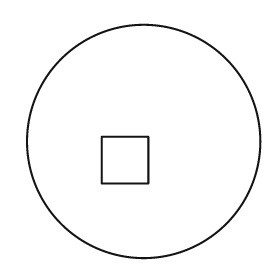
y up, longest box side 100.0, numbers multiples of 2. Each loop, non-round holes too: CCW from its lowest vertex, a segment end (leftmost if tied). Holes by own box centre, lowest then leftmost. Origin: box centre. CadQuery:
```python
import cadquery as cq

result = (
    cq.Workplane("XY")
    .moveTo(0.0, 0.0)
    .circle(50.0)
    .moveTo(-18.0, -18.0)
    .lineTo(2.0, -18.0)
    .lineTo(2.0, 2.0)
    .lineTo(-18.0, 2.0)
    .close()
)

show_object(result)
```